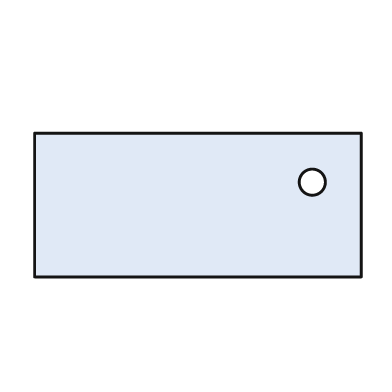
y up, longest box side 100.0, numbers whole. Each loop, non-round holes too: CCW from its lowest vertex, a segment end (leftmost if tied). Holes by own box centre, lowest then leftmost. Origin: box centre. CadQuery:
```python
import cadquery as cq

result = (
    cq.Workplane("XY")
    .moveTo(-50.0, -22.0)
    .lineTo(50.0, -22.0)
    .lineTo(50.0, 22.0)
    .lineTo(-50.0, 22.0)
    .close()
    .moveTo(35.0, 7.0)
    .circle(4.0)
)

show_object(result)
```